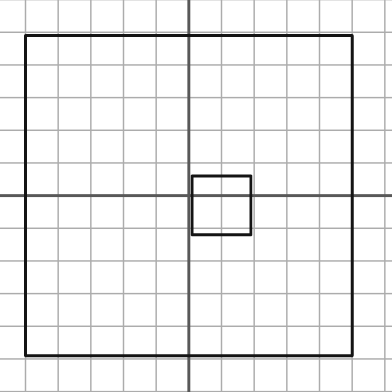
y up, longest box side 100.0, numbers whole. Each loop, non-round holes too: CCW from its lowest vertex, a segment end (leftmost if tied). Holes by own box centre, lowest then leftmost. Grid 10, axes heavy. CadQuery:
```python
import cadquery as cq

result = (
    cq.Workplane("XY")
    .moveTo(-50.0, -49.0)
    .lineTo(50.0, -49.0)
    .lineTo(50.0, 49.0)
    .lineTo(-50.0, 49.0)
    .close()
    .moveTo(1.0, -12.0)
    .lineTo(19.0, -12.0)
    .lineTo(19.0, 6.0)
    .lineTo(1.0, 6.0)
    .close()
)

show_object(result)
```